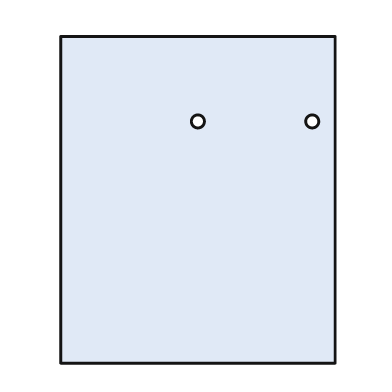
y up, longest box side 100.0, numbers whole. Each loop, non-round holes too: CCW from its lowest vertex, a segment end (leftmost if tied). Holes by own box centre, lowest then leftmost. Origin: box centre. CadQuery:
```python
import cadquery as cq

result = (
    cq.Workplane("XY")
    .moveTo(-42.0, -50.0)
    .lineTo(42.0, -50.0)
    .lineTo(42.0, 50.0)
    .lineTo(-42.0, 50.0)
    .close()
    .moveTo(0.0, 24.0)
    .circle(2.0)
    .moveTo(35.0, 24.0)
    .circle(2.0)
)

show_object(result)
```